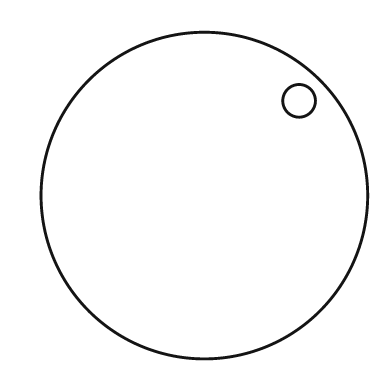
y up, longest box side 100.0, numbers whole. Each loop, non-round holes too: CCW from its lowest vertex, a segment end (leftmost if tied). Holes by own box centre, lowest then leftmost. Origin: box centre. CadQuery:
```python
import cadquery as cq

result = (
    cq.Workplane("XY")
    .moveTo(0.0, 0.0)
    .circle(50.0)
    .moveTo(29.0, 29.0)
    .circle(5.0)
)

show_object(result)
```